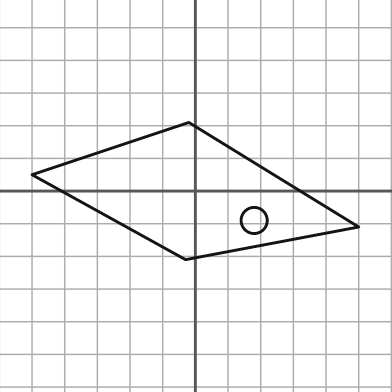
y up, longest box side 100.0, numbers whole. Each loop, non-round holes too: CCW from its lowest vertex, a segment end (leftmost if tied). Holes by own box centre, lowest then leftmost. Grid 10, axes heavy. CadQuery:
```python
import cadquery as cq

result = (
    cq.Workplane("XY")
    .moveTo(-3.0, -21.0)
    .lineTo(50.0, -11.0)
    .lineTo(-2.0, 21.0)
    .lineTo(-50.0, 5.0)
    .close()
    .moveTo(18.0, -9.0)
    .circle(4.0)
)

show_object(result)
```